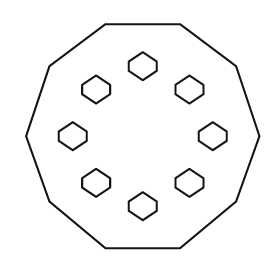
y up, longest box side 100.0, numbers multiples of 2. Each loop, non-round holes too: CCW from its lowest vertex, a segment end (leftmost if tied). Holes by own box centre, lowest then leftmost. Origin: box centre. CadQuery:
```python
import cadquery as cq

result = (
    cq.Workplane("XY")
    .moveTo(-16.0, -48.0)
    .lineTo(16.0, -48.0)
    .lineTo(40.0, -28.0)
    .lineTo(50.0, 0.0)
    .lineTo(40.0, 30.0)
    .lineTo(16.0, 48.0)
    .lineTo(-16.0, 48.0)
    .lineTo(-40.0, 30.0)
    .lineTo(-50.0, 0.0)
    .lineTo(-40.0, -28.0)
    .close()
    .moveTo(0.0, -36.0)
    .lineTo(6.0, -32.0)
    .lineTo(6.0, -28.0)
    .lineTo(0.0, -24.0)
    .lineTo(-6.0, -28.0)
    .lineTo(-6.0, -32.0)
    .close()
    .moveTo(-20.0, -26.0)
    .lineTo(-14.0, -22.0)
    .lineTo(-14.0, -18.0)
    .lineTo(-20.0, -14.0)
    .lineTo(-26.0, -18.0)
    .lineTo(-26.0, -22.0)
    .close()
    .moveTo(20.0, -26.0)
    .lineTo(26.0, -22.0)
    .lineTo(26.0, -18.0)
    .lineTo(20.0, -14.0)
    .lineTo(14.0, -18.0)
    .lineTo(14.0, -22.0)
    .close()
    .moveTo(-30.0, -6.0)
    .lineTo(-24.0, -2.0)
    .lineTo(-24.0, 2.0)
    .lineTo(-30.0, 6.0)
    .lineTo(-36.0, 2.0)
    .lineTo(-36.0, -2.0)
    .close()
    .moveTo(30.0, -6.0)
    .lineTo(36.0, -2.0)
    .lineTo(36.0, 2.0)
    .lineTo(30.0, 6.0)
    .lineTo(24.0, 2.0)
    .lineTo(24.0, -2.0)
    .close()
    .moveTo(-20.0, 14.0)
    .lineTo(-14.0, 18.0)
    .lineTo(-14.0, 22.0)
    .lineTo(-20.0, 26.0)
    .lineTo(-26.0, 22.0)
    .lineTo(-26.0, 18.0)
    .close()
    .moveTo(20.0, 14.0)
    .lineTo(26.0, 18.0)
    .lineTo(26.0, 22.0)
    .lineTo(20.0, 26.0)
    .lineTo(14.0, 22.0)
    .lineTo(14.0, 18.0)
    .close()
    .moveTo(0.0, 24.0)
    .lineTo(6.0, 28.0)
    .lineTo(6.0, 32.0)
    .lineTo(0.0, 36.0)
    .lineTo(-6.0, 32.0)
    .lineTo(-6.0, 28.0)
    .close()
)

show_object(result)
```